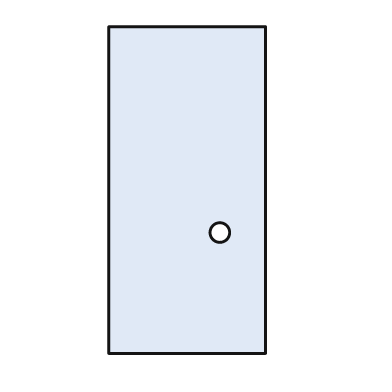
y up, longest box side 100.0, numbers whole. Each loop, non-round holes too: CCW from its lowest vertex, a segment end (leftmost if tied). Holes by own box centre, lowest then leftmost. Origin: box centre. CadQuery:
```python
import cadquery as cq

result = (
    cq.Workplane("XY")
    .moveTo(-24.0, -50.0)
    .lineTo(24.0, -50.0)
    .lineTo(24.0, 50.0)
    .lineTo(-24.0, 50.0)
    .close()
    .moveTo(10.0, -13.0)
    .circle(3.0)
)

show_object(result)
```